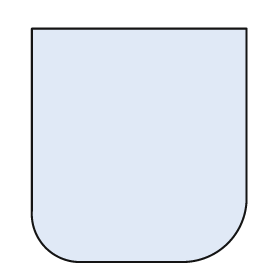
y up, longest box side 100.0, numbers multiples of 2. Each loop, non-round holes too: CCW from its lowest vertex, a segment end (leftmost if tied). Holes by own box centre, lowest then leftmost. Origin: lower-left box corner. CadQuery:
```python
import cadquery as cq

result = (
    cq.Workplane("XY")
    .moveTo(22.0, 0.0)
    .lineTo(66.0, 0.0)
    .threePointArc((84.0, 8.0), (92.0, 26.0))
    .lineTo(92.0, 100.0)
    .lineTo(0.0, 100.0)
    .lineTo(0.0, 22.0)
    .threePointArc((6.0, 6.0), (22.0, 0.0))
    .close()
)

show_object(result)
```